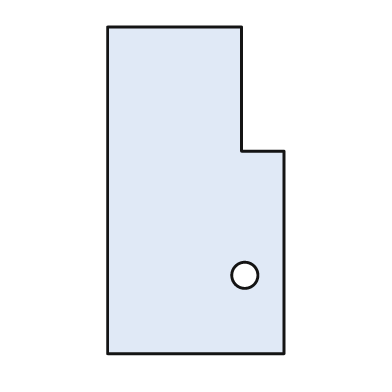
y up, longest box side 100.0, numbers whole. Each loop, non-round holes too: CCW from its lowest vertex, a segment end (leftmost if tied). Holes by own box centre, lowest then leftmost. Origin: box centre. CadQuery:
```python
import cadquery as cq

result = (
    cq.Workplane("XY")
    .moveTo(-27.0, -50.0)
    .lineTo(27.0, -50.0)
    .lineTo(27.0, 12.0)
    .lineTo(14.0, 12.0)
    .lineTo(14.0, 50.0)
    .lineTo(-27.0, 50.0)
    .close()
    .moveTo(15.0, -26.0)
    .circle(4.0)
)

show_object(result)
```